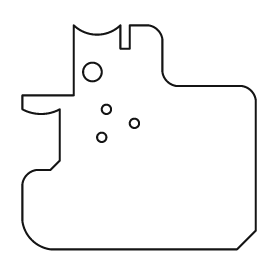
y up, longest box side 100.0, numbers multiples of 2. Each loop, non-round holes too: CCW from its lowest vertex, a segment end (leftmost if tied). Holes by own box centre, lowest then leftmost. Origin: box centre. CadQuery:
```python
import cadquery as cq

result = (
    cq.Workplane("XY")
    .moveTo(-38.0, -48.0)
    .lineTo(42.0, -48.0)
    .lineTo(50.0, -40.0)
    .lineTo(50.0, 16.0)
    .threePointArc((48.0, 20.0), (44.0, 22.0))
    .lineTo(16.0, 22.0)
    .threePointArc((12.0, 24.0), (10.0, 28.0))
    .lineTo(10.0, 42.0)
    .threePointArc((8.0, 46.0), (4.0, 48.0))
    .lineTo(-4.0, 48.0)
    .lineTo(-4.0, 38.0)
    .lineTo(-8.0, 38.0)
    .lineTo(-8.0, 48.0)
    .threePointArc((-18.0, 44.0), (-28.0, 48.0))
    .lineTo(-28.0, 18.0)
    .lineTo(-50.0, 18.0)
    .lineTo(-50.0, 12.0)
    .threePointArc((-42.0, 10.0), (-34.0, 12.0))
    .lineTo(-34.0, -10.0)
    .lineTo(-38.0, -14.0)
    .lineTo(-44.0, -14.0)
    .threePointArc((-48.0, -16.0), (-50.0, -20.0))
    .lineTo(-50.0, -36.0)
    .threePointArc((-46.0, -44.0), (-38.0, -48.0))
    .close()
    .moveTo(-16.0, 0.0)
    .circle(2.0)
    .moveTo(-2.0, 6.0)
    .circle(2.0)
    .moveTo(-14.0, 12.0)
    .circle(2.0)
    .moveTo(-20.0, 28.0)
    .circle(4.0)
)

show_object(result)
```